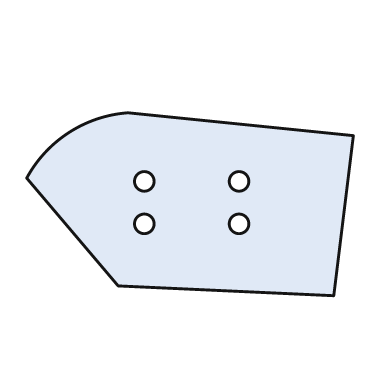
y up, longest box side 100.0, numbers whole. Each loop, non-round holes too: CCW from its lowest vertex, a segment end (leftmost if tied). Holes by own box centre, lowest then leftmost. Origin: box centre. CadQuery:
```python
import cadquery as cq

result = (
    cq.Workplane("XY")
    .moveTo(44.0, -28.0)
    .lineTo(50.0, 21.0)
    .lineTo(-19.0, 28.0)
    .threePointArc((-37.0, 22.0), (-50.0, 8.0))
    .lineTo(-22.0, -25.0)
    .close()
    .moveTo(-14.0, -6.0)
    .circle(3.0)
    .moveTo(15.0, -6.0)
    .circle(3.0)
    .moveTo(-14.0, 7.0)
    .circle(3.0)
    .moveTo(15.0, 7.0)
    .circle(3.0)
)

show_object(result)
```